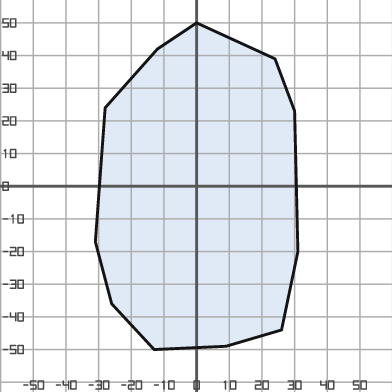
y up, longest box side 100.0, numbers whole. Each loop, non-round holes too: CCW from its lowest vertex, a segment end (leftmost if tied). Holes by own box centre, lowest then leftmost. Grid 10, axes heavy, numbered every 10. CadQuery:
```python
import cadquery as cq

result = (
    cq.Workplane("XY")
    .moveTo(-13.0, -50.0)
    .lineTo(9.0, -49.0)
    .lineTo(26.0, -44.0)
    .lineTo(31.0, -20.0)
    .lineTo(30.0, 23.0)
    .lineTo(24.0, 39.0)
    .lineTo(0.0, 50.0)
    .lineTo(-12.0, 42.0)
    .lineTo(-28.0, 24.0)
    .lineTo(-31.0, -17.0)
    .lineTo(-26.0, -36.0)
    .close()
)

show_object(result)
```